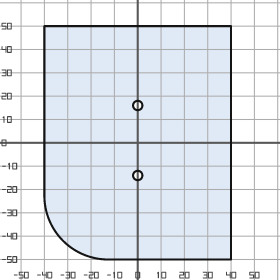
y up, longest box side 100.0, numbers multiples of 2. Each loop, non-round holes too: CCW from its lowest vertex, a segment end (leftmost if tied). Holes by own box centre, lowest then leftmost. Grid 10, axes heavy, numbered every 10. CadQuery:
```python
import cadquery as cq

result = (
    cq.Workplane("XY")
    .moveTo(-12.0, -50.0)
    .lineTo(40.0, -50.0)
    .lineTo(40.0, 50.0)
    .lineTo(-40.0, 50.0)
    .lineTo(-40.0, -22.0)
    .threePointArc((-32.0, -42.0), (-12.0, -50.0))
    .close()
    .moveTo(0.0, -14.0)
    .circle(2.0)
    .moveTo(0.0, 16.0)
    .circle(2.0)
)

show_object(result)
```